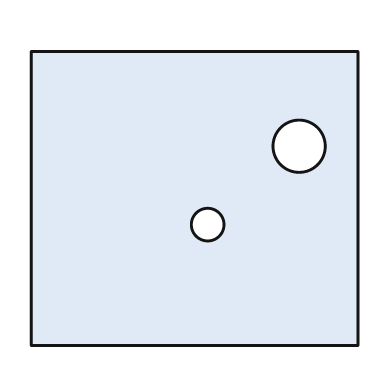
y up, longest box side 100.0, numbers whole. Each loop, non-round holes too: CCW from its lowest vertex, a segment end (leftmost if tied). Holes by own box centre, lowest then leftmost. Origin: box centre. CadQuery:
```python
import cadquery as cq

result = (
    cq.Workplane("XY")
    .moveTo(-50.0, -45.0)
    .lineTo(50.0, -45.0)
    .lineTo(50.0, 45.0)
    .lineTo(-50.0, 45.0)
    .close()
    .moveTo(4.0, -8.0)
    .circle(5.0)
    .moveTo(32.0, 16.0)
    .circle(8.0)
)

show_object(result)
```